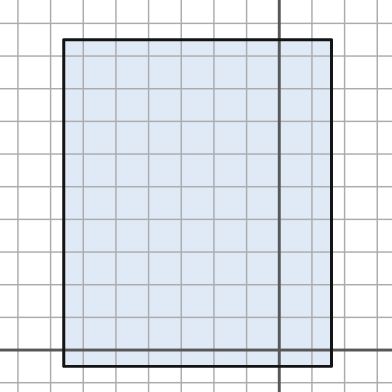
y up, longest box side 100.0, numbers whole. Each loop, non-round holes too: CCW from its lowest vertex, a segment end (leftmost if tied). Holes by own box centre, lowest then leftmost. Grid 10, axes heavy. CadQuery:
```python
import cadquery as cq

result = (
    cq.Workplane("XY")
    .moveTo(-66.0, -5.0)
    .lineTo(16.0, -5.0)
    .lineTo(16.0, 95.0)
    .lineTo(-66.0, 95.0)
    .close()
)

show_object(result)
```